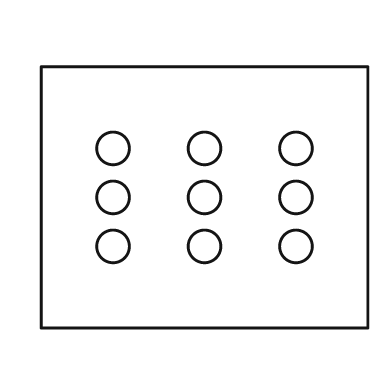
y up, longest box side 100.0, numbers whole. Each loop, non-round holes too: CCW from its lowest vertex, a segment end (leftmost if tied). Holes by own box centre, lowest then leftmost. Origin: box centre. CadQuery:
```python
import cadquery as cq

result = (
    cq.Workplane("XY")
    .moveTo(-50.0, -40.0)
    .lineTo(50.0, -40.0)
    .lineTo(50.0, 40.0)
    .lineTo(-50.0, 40.0)
    .close()
    .moveTo(-28.0, -15.0)
    .circle(5.0)
    .moveTo(0.0, -15.0)
    .circle(5.0)
    .moveTo(28.0, -15.0)
    .circle(5.0)
    .moveTo(-28.0, 0.0)
    .circle(5.0)
    .moveTo(0.0, 0.0)
    .circle(5.0)
    .moveTo(28.0, 0.0)
    .circle(5.0)
    .moveTo(-28.0, 15.0)
    .circle(5.0)
    .moveTo(0.0, 15.0)
    .circle(5.0)
    .moveTo(28.0, 15.0)
    .circle(5.0)
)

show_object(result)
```